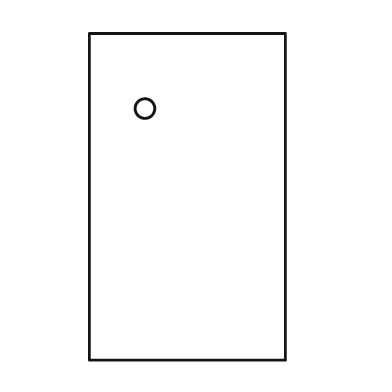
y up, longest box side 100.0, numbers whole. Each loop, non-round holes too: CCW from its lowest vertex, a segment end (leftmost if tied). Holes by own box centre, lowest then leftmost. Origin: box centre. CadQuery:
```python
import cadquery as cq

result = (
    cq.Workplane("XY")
    .moveTo(-30.0, -50.0)
    .lineTo(30.0, -50.0)
    .lineTo(30.0, 50.0)
    .lineTo(-30.0, 50.0)
    .close()
    .moveTo(-13.0, 27.0)
    .circle(3.0)
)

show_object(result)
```